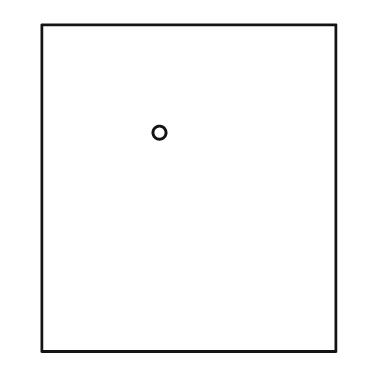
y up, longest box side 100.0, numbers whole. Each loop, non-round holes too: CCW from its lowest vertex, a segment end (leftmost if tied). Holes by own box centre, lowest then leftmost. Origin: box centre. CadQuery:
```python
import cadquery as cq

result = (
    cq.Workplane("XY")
    .moveTo(-45.0, -50.0)
    .lineTo(45.0, -50.0)
    .lineTo(45.0, 50.0)
    .lineTo(-45.0, 50.0)
    .close()
    .moveTo(-9.0, 17.0)
    .circle(2.0)
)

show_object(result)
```